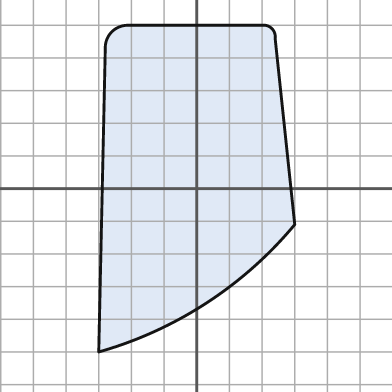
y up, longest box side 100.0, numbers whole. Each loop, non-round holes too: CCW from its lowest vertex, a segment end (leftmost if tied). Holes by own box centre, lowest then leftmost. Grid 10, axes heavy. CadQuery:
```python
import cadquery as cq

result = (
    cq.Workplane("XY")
    .moveTo(-30.0, -50.0)
    .threePointArc((3.0, -35.0), (30.0, -11.0))
    .lineTo(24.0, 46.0)
    .threePointArc((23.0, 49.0), (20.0, 50.0))
    .lineTo(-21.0, 50.0)
    .threePointArc((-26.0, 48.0), (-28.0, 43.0))
    .close()
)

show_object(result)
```